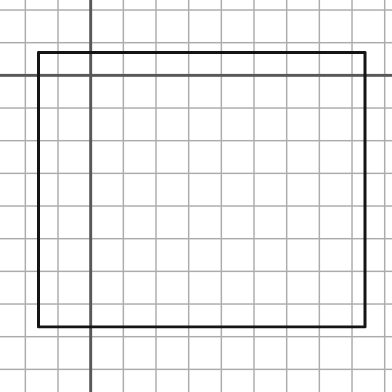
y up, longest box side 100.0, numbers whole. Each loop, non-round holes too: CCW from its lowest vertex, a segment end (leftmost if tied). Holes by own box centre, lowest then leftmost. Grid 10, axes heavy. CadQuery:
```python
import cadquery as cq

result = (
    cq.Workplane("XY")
    .moveTo(-16.0, -77.0)
    .lineTo(84.0, -77.0)
    .lineTo(84.0, 7.0)
    .lineTo(-16.0, 7.0)
    .close()
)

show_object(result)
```